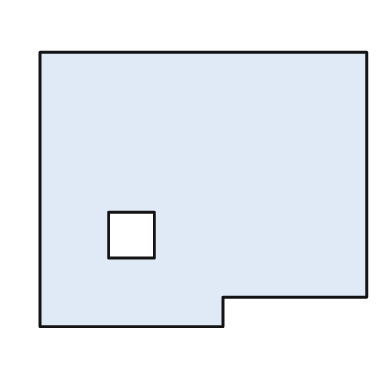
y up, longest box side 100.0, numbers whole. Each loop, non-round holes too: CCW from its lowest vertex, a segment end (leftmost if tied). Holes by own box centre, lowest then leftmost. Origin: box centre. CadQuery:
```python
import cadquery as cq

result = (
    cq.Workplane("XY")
    .moveTo(-50.0, -42.0)
    .lineTo(6.0, -42.0)
    .lineTo(6.0, -33.0)
    .lineTo(50.0, -33.0)
    .lineTo(50.0, 42.0)
    .lineTo(-50.0, 42.0)
    .close()
    .moveTo(-29.0, -21.0)
    .lineTo(-15.0, -21.0)
    .lineTo(-15.0, -7.0)
    .lineTo(-29.0, -7.0)
    .close()
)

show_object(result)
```